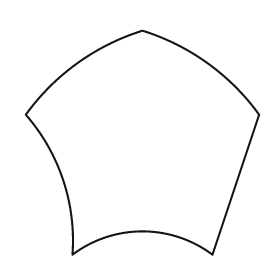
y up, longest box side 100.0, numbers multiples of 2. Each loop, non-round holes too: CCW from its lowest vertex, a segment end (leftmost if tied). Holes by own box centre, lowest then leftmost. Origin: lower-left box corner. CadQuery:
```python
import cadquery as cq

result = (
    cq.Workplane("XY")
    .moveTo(20.0, 0.0)
    .threePointArc((50.0, 10.0), (80.0, 0.0))
    .lineTo(100.0, 60.0)
    .threePointArc((78.0, 82.0), (50.0, 96.0))
    .threePointArc((22.0, 82.0), (0.0, 60.0))
    .threePointArc((16.0, 32.0), (20.0, 0.0))
    .close()
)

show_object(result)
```